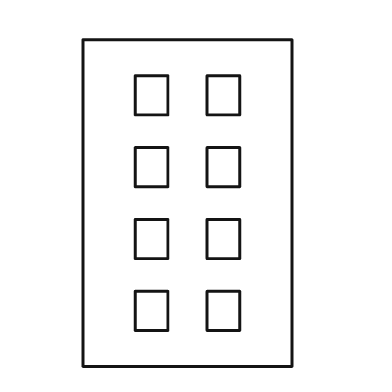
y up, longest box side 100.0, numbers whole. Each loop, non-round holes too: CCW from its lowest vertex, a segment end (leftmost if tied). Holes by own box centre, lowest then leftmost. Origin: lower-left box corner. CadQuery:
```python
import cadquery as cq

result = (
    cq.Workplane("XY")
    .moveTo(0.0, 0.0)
    .lineTo(64.0, 0.0)
    .lineTo(64.0, 100.0)
    .lineTo(0.0, 100.0)
    .close()
    .moveTo(16.0, 11.0)
    .lineTo(26.0, 11.0)
    .lineTo(26.0, 23.0)
    .lineTo(16.0, 23.0)
    .close()
    .moveTo(38.0, 11.0)
    .lineTo(48.0, 11.0)
    .lineTo(48.0, 23.0)
    .lineTo(38.0, 23.0)
    .close()
    .moveTo(16.0, 33.0)
    .lineTo(26.0, 33.0)
    .lineTo(26.0, 45.0)
    .lineTo(16.0, 45.0)
    .close()
    .moveTo(38.0, 33.0)
    .lineTo(48.0, 33.0)
    .lineTo(48.0, 45.0)
    .lineTo(38.0, 45.0)
    .close()
    .moveTo(16.0, 55.0)
    .lineTo(26.0, 55.0)
    .lineTo(26.0, 67.0)
    .lineTo(16.0, 67.0)
    .close()
    .moveTo(38.0, 55.0)
    .lineTo(48.0, 55.0)
    .lineTo(48.0, 67.0)
    .lineTo(38.0, 67.0)
    .close()
    .moveTo(16.0, 77.0)
    .lineTo(26.0, 77.0)
    .lineTo(26.0, 89.0)
    .lineTo(16.0, 89.0)
    .close()
    .moveTo(38.0, 77.0)
    .lineTo(48.0, 77.0)
    .lineTo(48.0, 89.0)
    .lineTo(38.0, 89.0)
    .close()
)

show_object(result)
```